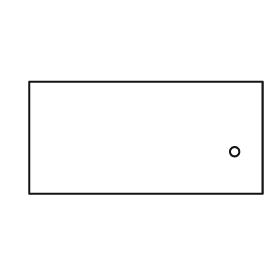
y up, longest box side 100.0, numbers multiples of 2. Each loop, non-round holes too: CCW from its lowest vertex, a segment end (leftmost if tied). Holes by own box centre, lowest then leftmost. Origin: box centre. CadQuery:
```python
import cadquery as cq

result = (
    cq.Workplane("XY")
    .moveTo(-50.0, -24.0)
    .lineTo(50.0, -24.0)
    .lineTo(50.0, 24.0)
    .lineTo(-50.0, 24.0)
    .close()
    .moveTo(38.0, -6.0)
    .circle(2.0)
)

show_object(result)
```